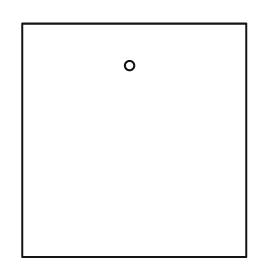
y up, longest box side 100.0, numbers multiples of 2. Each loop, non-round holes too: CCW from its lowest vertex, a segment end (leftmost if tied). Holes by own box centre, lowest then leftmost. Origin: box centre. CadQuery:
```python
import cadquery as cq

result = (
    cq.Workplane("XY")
    .moveTo(-48.0, -50.0)
    .lineTo(48.0, -50.0)
    .lineTo(48.0, 50.0)
    .lineTo(-48.0, 50.0)
    .close()
    .moveTo(-2.0, 32.0)
    .circle(2.0)
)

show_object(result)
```